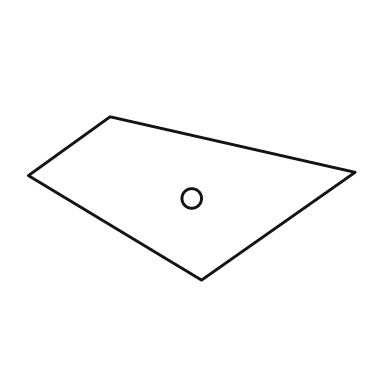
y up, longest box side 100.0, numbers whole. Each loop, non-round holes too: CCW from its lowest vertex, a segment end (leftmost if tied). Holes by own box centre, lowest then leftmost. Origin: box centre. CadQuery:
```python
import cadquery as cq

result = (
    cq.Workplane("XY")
    .moveTo(3.0, -25.0)
    .lineTo(50.0, 8.0)
    .lineTo(-25.0, 25.0)
    .lineTo(-50.0, 7.0)
    .close()
    .moveTo(0.0, 0.0)
    .circle(3.0)
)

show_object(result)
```